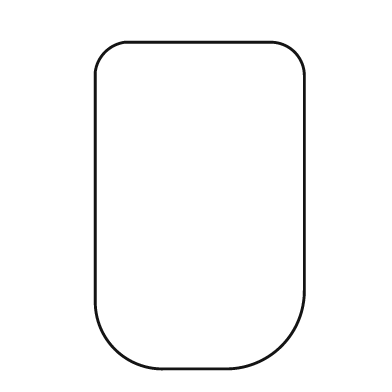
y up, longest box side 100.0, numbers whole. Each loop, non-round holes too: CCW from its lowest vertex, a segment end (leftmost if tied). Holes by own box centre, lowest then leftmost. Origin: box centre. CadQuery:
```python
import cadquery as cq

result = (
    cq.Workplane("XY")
    .moveTo(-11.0, -50.0)
    .lineTo(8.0, -50.0)
    .threePointArc((25.0, -43.0), (32.0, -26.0))
    .lineTo(32.0, 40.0)
    .threePointArc((29.0, 47.0), (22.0, 50.0))
    .lineTo(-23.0, 50.0)
    .threePointArc((-29.0, 47.0), (-32.0, 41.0))
    .lineTo(-32.0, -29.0)
    .threePointArc((-26.0, -44.0), (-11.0, -50.0))
    .close()
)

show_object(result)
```